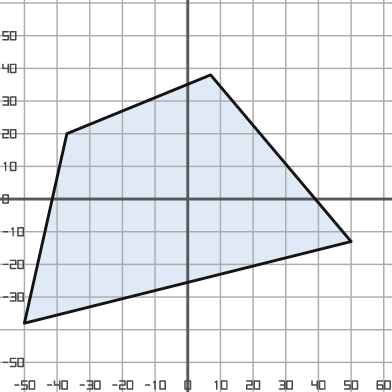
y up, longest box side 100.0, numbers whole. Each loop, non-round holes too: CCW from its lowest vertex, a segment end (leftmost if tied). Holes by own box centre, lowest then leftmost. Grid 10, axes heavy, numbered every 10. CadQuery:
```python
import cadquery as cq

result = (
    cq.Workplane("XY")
    .moveTo(-50.0, -38.0)
    .lineTo(50.0, -13.0)
    .lineTo(7.0, 38.0)
    .lineTo(-37.0, 20.0)
    .close()
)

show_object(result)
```